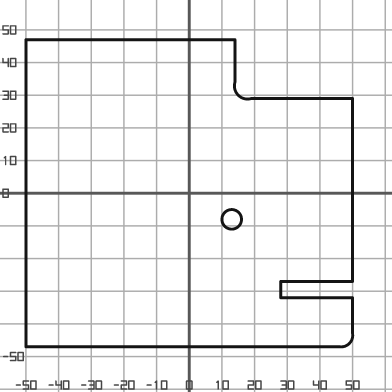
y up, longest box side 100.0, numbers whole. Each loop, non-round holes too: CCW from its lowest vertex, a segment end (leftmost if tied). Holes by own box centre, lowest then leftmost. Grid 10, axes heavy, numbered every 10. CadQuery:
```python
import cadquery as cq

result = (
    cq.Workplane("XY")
    .moveTo(-50.0, -47.0)
    .lineTo(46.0, -47.0)
    .threePointArc((49.0, -46.0), (50.0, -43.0))
    .lineTo(50.0, -32.0)
    .lineTo(28.0, -32.0)
    .lineTo(28.0, -27.0)
    .lineTo(50.0, -27.0)
    .lineTo(50.0, 29.0)
    .lineTo(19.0, 29.0)
    .threePointArc((15.0, 30.0), (14.0, 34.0))
    .lineTo(14.0, 47.0)
    .lineTo(-50.0, 47.0)
    .close()
    .moveTo(13.0, -8.0)
    .circle(3.0)
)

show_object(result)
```